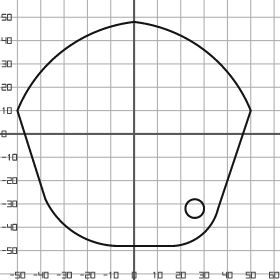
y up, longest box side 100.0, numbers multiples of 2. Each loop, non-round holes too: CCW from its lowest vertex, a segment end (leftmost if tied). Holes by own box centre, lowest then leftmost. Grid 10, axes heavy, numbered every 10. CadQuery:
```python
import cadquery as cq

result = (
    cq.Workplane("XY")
    .moveTo(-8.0, -48.0)
    .lineTo(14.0, -48.0)
    .threePointArc((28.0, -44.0), (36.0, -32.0))
    .lineTo(50.0, 10.0)
    .threePointArc((30.0, 36.0), (0.0, 48.0))
    .threePointArc((-30.0, 36.0), (-50.0, 10.0))
    .lineTo(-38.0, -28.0)
    .threePointArc((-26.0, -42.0), (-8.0, -48.0))
    .close()
    .moveTo(26.0, -32.0)
    .circle(4.0)
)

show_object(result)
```